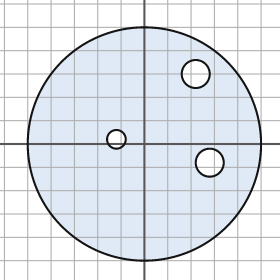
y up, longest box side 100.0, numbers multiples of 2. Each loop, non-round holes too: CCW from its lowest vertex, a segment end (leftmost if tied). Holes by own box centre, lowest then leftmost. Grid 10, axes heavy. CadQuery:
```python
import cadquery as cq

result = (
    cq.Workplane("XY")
    .moveTo(0.0, 0.0)
    .circle(50.0)
    .moveTo(28.0, -8.0)
    .circle(6.0)
    .moveTo(-12.0, 2.0)
    .circle(4.0)
    .moveTo(22.0, 30.0)
    .circle(6.0)
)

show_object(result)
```